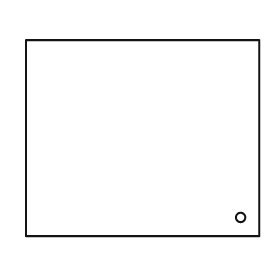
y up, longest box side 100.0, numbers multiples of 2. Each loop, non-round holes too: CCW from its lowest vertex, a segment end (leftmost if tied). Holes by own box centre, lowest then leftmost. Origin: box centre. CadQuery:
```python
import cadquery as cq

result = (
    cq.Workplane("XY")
    .moveTo(-50.0, -42.0)
    .lineTo(50.0, -42.0)
    .lineTo(50.0, 42.0)
    .lineTo(-50.0, 42.0)
    .close()
    .moveTo(42.0, -34.0)
    .circle(2.0)
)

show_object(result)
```